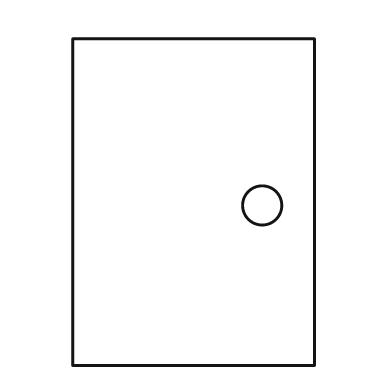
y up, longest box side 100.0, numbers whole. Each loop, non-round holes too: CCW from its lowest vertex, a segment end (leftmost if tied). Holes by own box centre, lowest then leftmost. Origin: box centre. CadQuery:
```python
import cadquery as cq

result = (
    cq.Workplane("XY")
    .moveTo(-37.0, -50.0)
    .lineTo(37.0, -50.0)
    .lineTo(37.0, 50.0)
    .lineTo(-37.0, 50.0)
    .close()
    .moveTo(21.0, -1.0)
    .circle(6.0)
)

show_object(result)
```